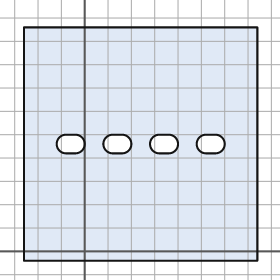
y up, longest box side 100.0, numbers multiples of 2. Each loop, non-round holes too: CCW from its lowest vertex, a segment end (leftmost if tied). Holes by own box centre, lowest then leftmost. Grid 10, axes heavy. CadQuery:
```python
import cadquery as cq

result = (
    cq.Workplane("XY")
    .moveTo(-26.0, -4.0)
    .lineTo(74.0, -4.0)
    .lineTo(74.0, 96.0)
    .lineTo(-26.0, 96.0)
    .close()
    .moveTo(-8.0, 42.0)
    .lineTo(-4.0, 42.0)
    .threePointArc((0.0, 46.0), (-4.0, 50.0))
    .lineTo(-8.0, 50.0)
    .threePointArc((-12.0, 46.0), (-8.0, 42.0))
    .close()
    .moveTo(12.0, 42.0)
    .lineTo(16.0, 42.0)
    .threePointArc((20.0, 46.0), (16.0, 50.0))
    .lineTo(12.0, 50.0)
    .threePointArc((8.0, 46.0), (12.0, 42.0))
    .close()
    .moveTo(32.0, 42.0)
    .lineTo(36.0, 42.0)
    .threePointArc((40.0, 46.0), (36.0, 50.0))
    .lineTo(32.0, 50.0)
    .threePointArc((28.0, 46.0), (32.0, 42.0))
    .close()
    .moveTo(52.0, 42.0)
    .lineTo(56.0, 42.0)
    .threePointArc((60.0, 46.0), (56.0, 50.0))
    .lineTo(52.0, 50.0)
    .threePointArc((48.0, 46.0), (52.0, 42.0))
    .close()
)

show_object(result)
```